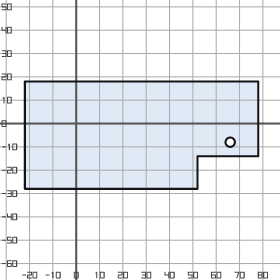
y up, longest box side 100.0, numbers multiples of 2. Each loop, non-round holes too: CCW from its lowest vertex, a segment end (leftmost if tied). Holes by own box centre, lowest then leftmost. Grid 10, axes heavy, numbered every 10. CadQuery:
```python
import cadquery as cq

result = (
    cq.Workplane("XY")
    .moveTo(-22.0, -28.0)
    .lineTo(52.0, -28.0)
    .lineTo(52.0, -14.0)
    .lineTo(78.0, -14.0)
    .lineTo(78.0, 18.0)
    .lineTo(-22.0, 18.0)
    .close()
    .moveTo(66.0, -8.0)
    .circle(2.0)
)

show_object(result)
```